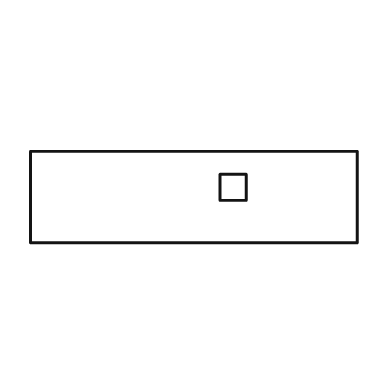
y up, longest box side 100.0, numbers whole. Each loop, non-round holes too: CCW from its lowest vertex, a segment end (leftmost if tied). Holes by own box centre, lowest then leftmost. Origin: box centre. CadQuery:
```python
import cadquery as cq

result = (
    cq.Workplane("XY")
    .moveTo(-50.0, -14.0)
    .lineTo(50.0, -14.0)
    .lineTo(50.0, 14.0)
    .lineTo(-50.0, 14.0)
    .close()
    .moveTo(8.0, -1.0)
    .lineTo(16.0, -1.0)
    .lineTo(16.0, 7.0)
    .lineTo(8.0, 7.0)
    .close()
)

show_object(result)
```